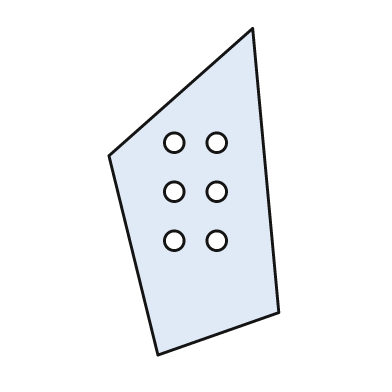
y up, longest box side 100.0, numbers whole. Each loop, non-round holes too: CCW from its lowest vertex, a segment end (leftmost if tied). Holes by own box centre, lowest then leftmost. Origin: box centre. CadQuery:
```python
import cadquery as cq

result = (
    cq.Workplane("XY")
    .moveTo(-11.0, -50.0)
    .lineTo(26.0, -37.0)
    .lineTo(18.0, 50.0)
    .lineTo(-26.0, 11.0)
    .close()
    .moveTo(-6.0, -15.0)
    .circle(3.0)
    .moveTo(7.0, -15.0)
    .circle(3.0)
    .moveTo(-6.0, 0.0)
    .circle(3.0)
    .moveTo(7.0, 0.0)
    .circle(3.0)
    .moveTo(-6.0, 15.0)
    .circle(3.0)
    .moveTo(7.0, 15.0)
    .circle(3.0)
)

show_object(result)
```